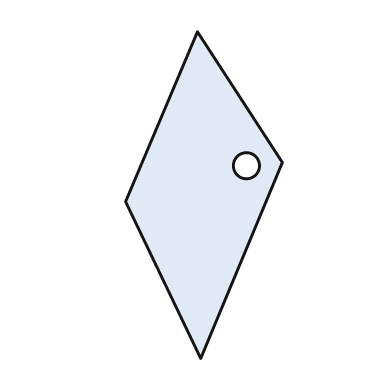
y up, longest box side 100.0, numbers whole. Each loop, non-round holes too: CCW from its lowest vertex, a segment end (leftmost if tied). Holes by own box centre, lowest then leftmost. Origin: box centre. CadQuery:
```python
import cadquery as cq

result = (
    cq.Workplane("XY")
    .moveTo(-1.0, -50.0)
    .lineTo(24.0, 10.0)
    .lineTo(-2.0, 50.0)
    .lineTo(-24.0, -2.0)
    .close()
    .moveTo(13.0, 9.0)
    .circle(4.0)
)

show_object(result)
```